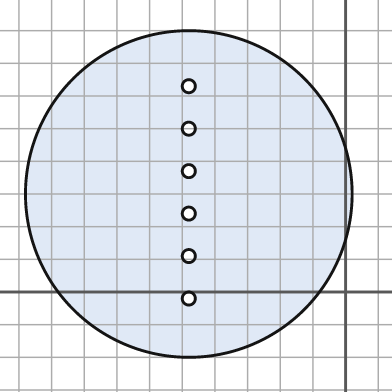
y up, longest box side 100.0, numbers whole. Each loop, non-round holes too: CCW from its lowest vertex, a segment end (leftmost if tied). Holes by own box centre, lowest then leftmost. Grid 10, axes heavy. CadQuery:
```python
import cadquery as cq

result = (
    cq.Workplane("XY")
    .moveTo(-48.0, 30.0)
    .circle(50.0)
    .moveTo(-48.0, -2.0)
    .circle(2.0)
    .moveTo(-48.0, 11.0)
    .circle(2.0)
    .moveTo(-48.0, 24.0)
    .circle(2.0)
    .moveTo(-48.0, 37.0)
    .circle(2.0)
    .moveTo(-48.0, 50.0)
    .circle(2.0)
    .moveTo(-48.0, 63.0)
    .circle(2.0)
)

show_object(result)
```